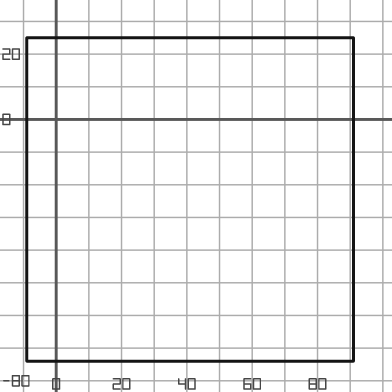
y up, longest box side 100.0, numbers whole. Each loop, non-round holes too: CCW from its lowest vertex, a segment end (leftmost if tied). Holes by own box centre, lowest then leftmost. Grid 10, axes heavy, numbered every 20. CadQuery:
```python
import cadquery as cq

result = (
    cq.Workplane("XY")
    .moveTo(-9.0, -74.0)
    .lineTo(91.0, -74.0)
    .lineTo(91.0, 25.0)
    .lineTo(-9.0, 25.0)
    .close()
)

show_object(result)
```